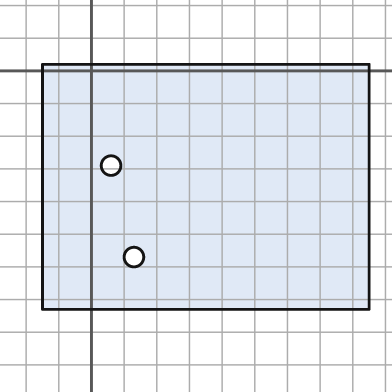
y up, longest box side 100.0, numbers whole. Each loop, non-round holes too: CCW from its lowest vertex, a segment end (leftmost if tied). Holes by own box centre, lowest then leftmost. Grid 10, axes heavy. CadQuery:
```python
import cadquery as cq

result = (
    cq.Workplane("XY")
    .moveTo(-15.0, -73.0)
    .lineTo(85.0, -73.0)
    .lineTo(85.0, 2.0)
    .lineTo(-15.0, 2.0)
    .close()
    .moveTo(13.0, -57.0)
    .circle(3.0)
    .moveTo(6.0, -29.0)
    .circle(3.0)
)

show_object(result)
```